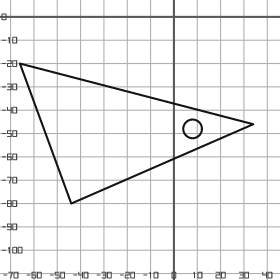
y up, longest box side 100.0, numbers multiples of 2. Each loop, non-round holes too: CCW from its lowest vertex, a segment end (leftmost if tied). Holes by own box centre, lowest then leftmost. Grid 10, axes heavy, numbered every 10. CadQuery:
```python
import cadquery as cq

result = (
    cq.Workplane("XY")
    .moveTo(-44.0, -80.0)
    .lineTo(34.0, -46.0)
    .lineTo(-66.0, -20.0)
    .close()
    .moveTo(8.0, -48.0)
    .circle(4.0)
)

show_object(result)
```